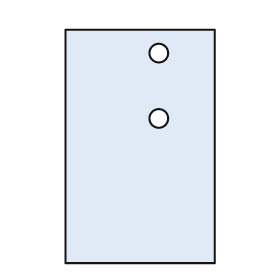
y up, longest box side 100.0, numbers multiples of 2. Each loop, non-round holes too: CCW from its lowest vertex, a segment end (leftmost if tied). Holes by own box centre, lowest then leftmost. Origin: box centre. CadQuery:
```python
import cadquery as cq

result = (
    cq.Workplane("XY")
    .moveTo(-32.0, -50.0)
    .lineTo(32.0, -50.0)
    .lineTo(32.0, 50.0)
    .lineTo(-32.0, 50.0)
    .close()
    .moveTo(8.0, 12.0)
    .circle(4.0)
    .moveTo(8.0, 40.0)
    .circle(4.0)
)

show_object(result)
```